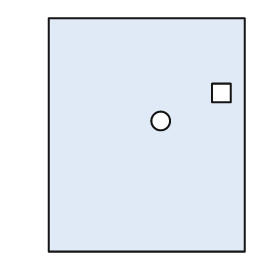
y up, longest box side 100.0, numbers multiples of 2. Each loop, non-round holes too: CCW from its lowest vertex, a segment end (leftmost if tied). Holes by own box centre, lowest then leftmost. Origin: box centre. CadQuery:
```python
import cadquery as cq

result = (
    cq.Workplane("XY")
    .moveTo(-42.0, -50.0)
    .lineTo(42.0, -50.0)
    .lineTo(42.0, 50.0)
    .lineTo(-42.0, 50.0)
    .close()
    .moveTo(6.0, 6.0)
    .circle(4.0)
    .moveTo(28.0, 14.0)
    .lineTo(36.0, 14.0)
    .lineTo(36.0, 22.0)
    .lineTo(28.0, 22.0)
    .close()
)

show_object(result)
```